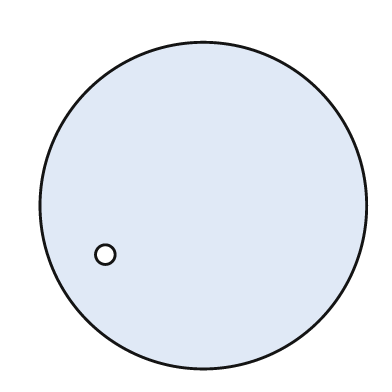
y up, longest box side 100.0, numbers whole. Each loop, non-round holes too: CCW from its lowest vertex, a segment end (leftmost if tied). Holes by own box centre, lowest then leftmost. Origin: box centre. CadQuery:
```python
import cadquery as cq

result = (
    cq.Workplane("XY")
    .moveTo(0.0, 0.0)
    .circle(50.0)
    .moveTo(-30.0, -15.0)
    .circle(3.0)
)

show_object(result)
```